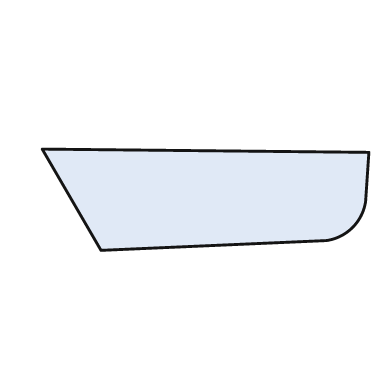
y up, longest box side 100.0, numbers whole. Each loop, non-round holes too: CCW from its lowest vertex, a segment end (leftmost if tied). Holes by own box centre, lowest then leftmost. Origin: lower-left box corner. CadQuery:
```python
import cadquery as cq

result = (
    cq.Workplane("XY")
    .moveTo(18.0, 0.0)
    .lineTo(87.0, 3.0)
    .threePointArc((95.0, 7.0), (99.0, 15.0))
    .lineTo(100.0, 30.0)
    .lineTo(0.0, 31.0)
    .close()
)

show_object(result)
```